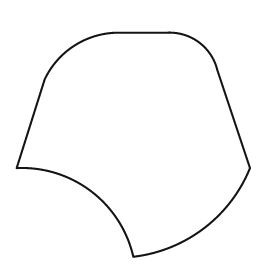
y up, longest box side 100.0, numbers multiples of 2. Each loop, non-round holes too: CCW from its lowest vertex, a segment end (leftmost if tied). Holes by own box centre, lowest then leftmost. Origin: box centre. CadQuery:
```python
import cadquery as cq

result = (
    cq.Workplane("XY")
    .moveTo(0.0, -48.0)
    .threePointArc((30.0, -36.0), (50.0, -10.0))
    .lineTo(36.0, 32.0)
    .threePointArc((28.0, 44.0), (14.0, 48.0))
    .lineTo(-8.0, 48.0)
    .threePointArc((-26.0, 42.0), (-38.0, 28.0))
    .lineTo(-50.0, -10.0)
    .threePointArc((-18.0, -20.0), (0.0, -48.0))
    .close()
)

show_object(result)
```